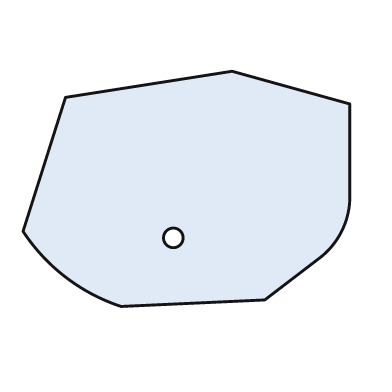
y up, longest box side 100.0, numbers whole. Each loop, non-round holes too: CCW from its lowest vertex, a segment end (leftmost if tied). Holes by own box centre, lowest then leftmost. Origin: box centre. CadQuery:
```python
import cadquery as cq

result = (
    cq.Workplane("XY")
    .moveTo(-20.0, -36.0)
    .lineTo(24.0, -34.0)
    .lineTo(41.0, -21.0)
    .threePointArc((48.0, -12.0), (50.0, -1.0))
    .lineTo(50.0, 26.0)
    .lineTo(14.0, 36.0)
    .lineTo(-37.0, 28.0)
    .lineTo(-50.0, -13.0)
    .threePointArc((-37.0, -27.0), (-20.0, -36.0))
    .close()
    .moveTo(-4.0, -15.0)
    .circle(3.0)
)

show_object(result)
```